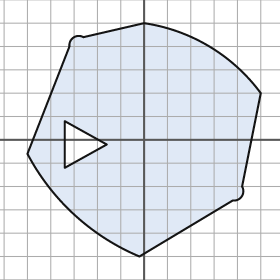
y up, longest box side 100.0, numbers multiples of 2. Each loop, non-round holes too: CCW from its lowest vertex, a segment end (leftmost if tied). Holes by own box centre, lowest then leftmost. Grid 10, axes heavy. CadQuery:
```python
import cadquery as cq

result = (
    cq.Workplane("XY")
    .moveTo(-2.0, -50.0)
    .lineTo(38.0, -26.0)
    .threePointArc((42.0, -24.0), (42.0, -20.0))
    .lineTo(50.0, 20.0)
    .threePointArc((28.0, 40.0), (0.0, 50.0))
    .lineTo(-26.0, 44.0)
    .threePointArc((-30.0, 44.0), (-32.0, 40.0))
    .lineTo(-50.0, -6.0)
    .threePointArc((-30.0, -32.0), (-2.0, -50.0))
    .close()
    .moveTo(-34.0, -12.0)
    .lineTo(-16.0, -2.0)
    .lineTo(-34.0, 8.0)
    .close()
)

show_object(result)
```